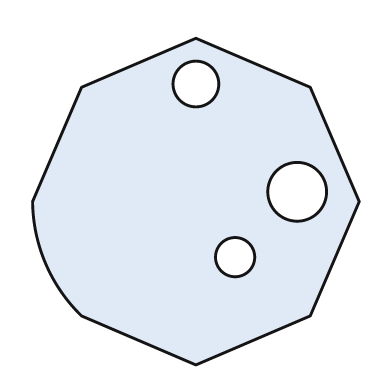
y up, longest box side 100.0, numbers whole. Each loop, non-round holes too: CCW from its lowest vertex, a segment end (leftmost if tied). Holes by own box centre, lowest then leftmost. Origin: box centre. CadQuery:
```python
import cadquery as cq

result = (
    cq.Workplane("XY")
    .moveTo(0.0, -50.0)
    .lineTo(35.0, -35.0)
    .lineTo(50.0, 0.0)
    .lineTo(35.0, 35.0)
    .lineTo(0.0, 50.0)
    .lineTo(-35.0, 35.0)
    .lineTo(-50.0, 0.0)
    .threePointArc((-46.0, -19.0), (-35.0, -35.0))
    .close()
    .moveTo(12.0, -17.0)
    .circle(6.0)
    .moveTo(31.0, 3.0)
    .circle(9.0)
    .moveTo(0.0, 36.0)
    .circle(7.0)
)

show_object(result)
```